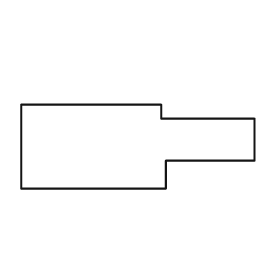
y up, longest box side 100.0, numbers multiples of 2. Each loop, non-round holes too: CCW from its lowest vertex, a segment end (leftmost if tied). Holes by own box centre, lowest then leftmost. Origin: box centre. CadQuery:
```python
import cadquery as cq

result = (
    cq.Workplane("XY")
    .moveTo(-50.0, -18.0)
    .lineTo(12.0, -18.0)
    .lineTo(12.0, -6.0)
    .lineTo(50.0, -6.0)
    .lineTo(50.0, 12.0)
    .lineTo(10.0, 12.0)
    .lineTo(10.0, 18.0)
    .lineTo(-50.0, 18.0)
    .close()
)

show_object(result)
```